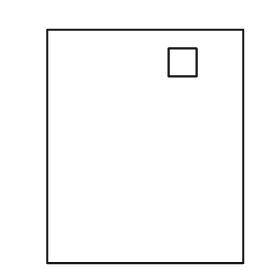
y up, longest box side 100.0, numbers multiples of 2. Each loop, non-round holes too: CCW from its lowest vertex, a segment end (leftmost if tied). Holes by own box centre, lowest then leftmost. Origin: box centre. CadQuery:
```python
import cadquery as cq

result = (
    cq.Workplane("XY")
    .moveTo(-42.0, -50.0)
    .lineTo(42.0, -50.0)
    .lineTo(42.0, 50.0)
    .lineTo(-42.0, 50.0)
    .close()
    .moveTo(10.0, 30.0)
    .lineTo(22.0, 30.0)
    .lineTo(22.0, 42.0)
    .lineTo(10.0, 42.0)
    .close()
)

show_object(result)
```